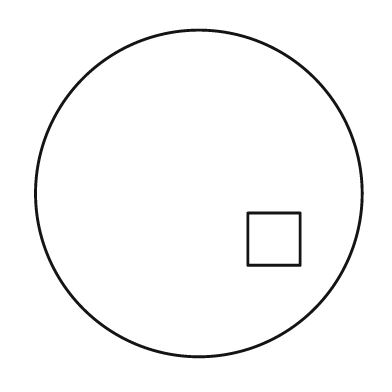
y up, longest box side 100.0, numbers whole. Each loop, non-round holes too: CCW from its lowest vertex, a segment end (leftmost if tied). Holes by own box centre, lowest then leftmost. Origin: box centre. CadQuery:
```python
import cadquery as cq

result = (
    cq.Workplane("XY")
    .moveTo(0.0, 0.0)
    .circle(50.0)
    .moveTo(15.0, -22.0)
    .lineTo(31.0, -22.0)
    .lineTo(31.0, -6.0)
    .lineTo(15.0, -6.0)
    .close()
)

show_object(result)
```